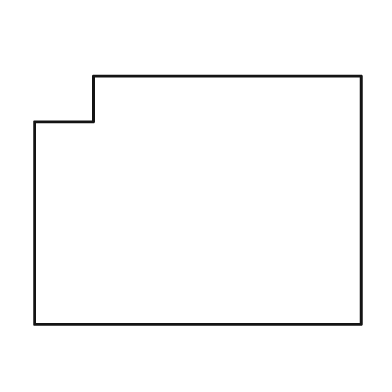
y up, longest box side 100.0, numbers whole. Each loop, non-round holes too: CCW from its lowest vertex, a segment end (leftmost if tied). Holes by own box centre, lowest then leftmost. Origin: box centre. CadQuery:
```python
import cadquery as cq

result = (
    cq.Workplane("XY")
    .moveTo(-50.0, -38.0)
    .lineTo(50.0, -38.0)
    .lineTo(50.0, 38.0)
    .lineTo(-32.0, 38.0)
    .lineTo(-32.0, 24.0)
    .lineTo(-50.0, 24.0)
    .close()
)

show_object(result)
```